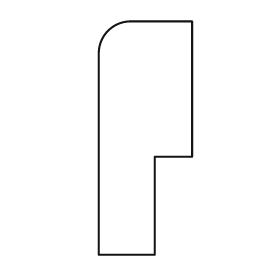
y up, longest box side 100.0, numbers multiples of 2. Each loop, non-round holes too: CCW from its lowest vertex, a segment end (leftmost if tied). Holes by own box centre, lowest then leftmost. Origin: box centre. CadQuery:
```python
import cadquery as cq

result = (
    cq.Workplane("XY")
    .moveTo(-20.0, -50.0)
    .lineTo(4.0, -50.0)
    .lineTo(4.0, -8.0)
    .lineTo(20.0, -8.0)
    .lineTo(20.0, 50.0)
    .lineTo(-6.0, 50.0)
    .threePointArc((-16.0, 46.0), (-20.0, 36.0))
    .close()
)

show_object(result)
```